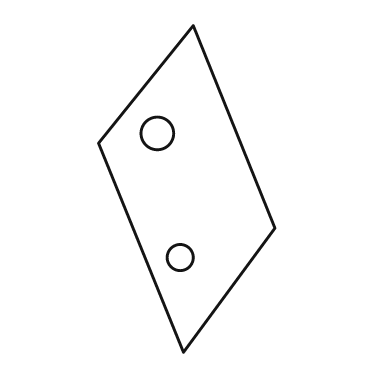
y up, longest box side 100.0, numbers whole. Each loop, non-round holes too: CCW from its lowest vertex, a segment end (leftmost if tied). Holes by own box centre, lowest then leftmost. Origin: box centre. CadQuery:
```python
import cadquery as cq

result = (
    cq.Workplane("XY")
    .moveTo(-1.0, -50.0)
    .lineTo(27.0, -12.0)
    .lineTo(2.0, 50.0)
    .lineTo(-27.0, 14.0)
    .close()
    .moveTo(-2.0, -21.0)
    .circle(4.0)
    .moveTo(-9.0, 17.0)
    .circle(5.0)
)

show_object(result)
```